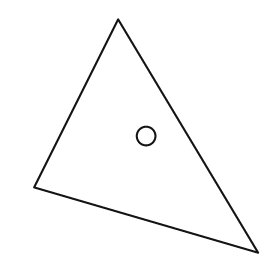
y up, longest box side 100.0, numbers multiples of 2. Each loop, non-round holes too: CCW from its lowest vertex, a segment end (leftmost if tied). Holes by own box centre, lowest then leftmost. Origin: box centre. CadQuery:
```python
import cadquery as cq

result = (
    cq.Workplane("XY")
    .moveTo(48.0, -50.0)
    .lineTo(-12.0, 50.0)
    .lineTo(-48.0, -22.0)
    .close()
    .moveTo(0.0, 0.0)
    .circle(4.0)
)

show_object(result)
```